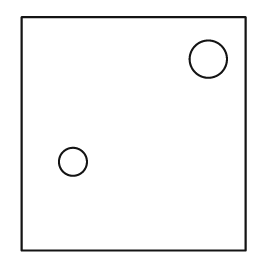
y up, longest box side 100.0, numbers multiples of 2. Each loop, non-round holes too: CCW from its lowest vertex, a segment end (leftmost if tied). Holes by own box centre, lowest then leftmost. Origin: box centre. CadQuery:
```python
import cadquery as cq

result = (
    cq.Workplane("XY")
    .moveTo(-48.0, -50.0)
    .lineTo(48.0, -50.0)
    .lineTo(48.0, 50.0)
    .lineTo(-48.0, 50.0)
    .close()
    .moveTo(-26.0, -12.0)
    .circle(6.0)
    .moveTo(32.0, 32.0)
    .circle(8.0)
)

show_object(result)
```